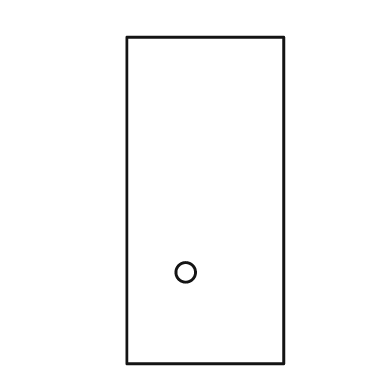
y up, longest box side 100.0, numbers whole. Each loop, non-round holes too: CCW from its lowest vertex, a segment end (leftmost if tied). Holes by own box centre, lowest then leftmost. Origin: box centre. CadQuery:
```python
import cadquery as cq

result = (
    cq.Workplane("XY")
    .moveTo(-24.0, -50.0)
    .lineTo(24.0, -50.0)
    .lineTo(24.0, 50.0)
    .lineTo(-24.0, 50.0)
    .close()
    .moveTo(-6.0, -22.0)
    .circle(3.0)
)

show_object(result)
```